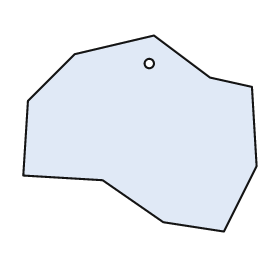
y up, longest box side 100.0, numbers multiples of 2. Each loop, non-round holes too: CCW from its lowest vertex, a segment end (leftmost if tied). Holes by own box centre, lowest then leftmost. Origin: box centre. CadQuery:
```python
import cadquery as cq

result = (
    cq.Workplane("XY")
    .moveTo(36.0, -42.0)
    .lineTo(50.0, -14.0)
    .lineTo(48.0, 20.0)
    .lineTo(30.0, 24.0)
    .lineTo(6.0, 42.0)
    .lineTo(-28.0, 34.0)
    .lineTo(-48.0, 14.0)
    .lineTo(-50.0, -18.0)
    .lineTo(-16.0, -20.0)
    .lineTo(10.0, -38.0)
    .close()
    .moveTo(4.0, 30.0)
    .circle(2.0)
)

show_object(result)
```